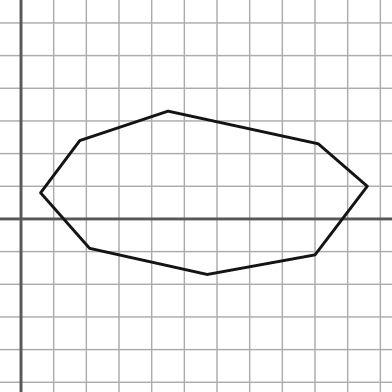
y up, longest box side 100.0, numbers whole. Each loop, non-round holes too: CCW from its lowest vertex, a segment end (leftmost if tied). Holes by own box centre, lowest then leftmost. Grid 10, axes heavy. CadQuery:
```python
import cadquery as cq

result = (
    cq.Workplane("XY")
    .moveTo(57.0, -17.0)
    .lineTo(90.0, -11.0)
    .lineTo(106.0, 10.0)
    .lineTo(91.0, 23.0)
    .lineTo(45.0, 33.0)
    .lineTo(18.0, 24.0)
    .lineTo(6.0, 8.0)
    .lineTo(21.0, -9.0)
    .close()
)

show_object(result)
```